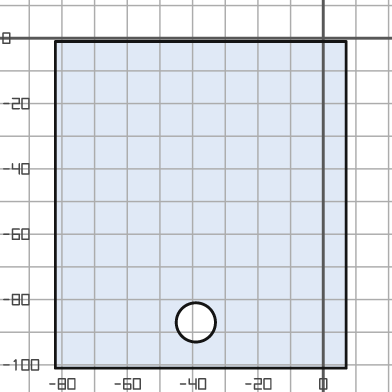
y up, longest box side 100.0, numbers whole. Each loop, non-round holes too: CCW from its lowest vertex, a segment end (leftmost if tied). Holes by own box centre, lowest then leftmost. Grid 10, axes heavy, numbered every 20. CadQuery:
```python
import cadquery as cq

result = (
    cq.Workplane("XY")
    .moveTo(-82.0, -101.0)
    .lineTo(7.0, -101.0)
    .lineTo(7.0, -1.0)
    .lineTo(-82.0, -1.0)
    .close()
    .moveTo(-39.0, -87.0)
    .circle(6.0)
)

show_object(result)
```